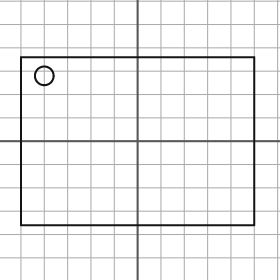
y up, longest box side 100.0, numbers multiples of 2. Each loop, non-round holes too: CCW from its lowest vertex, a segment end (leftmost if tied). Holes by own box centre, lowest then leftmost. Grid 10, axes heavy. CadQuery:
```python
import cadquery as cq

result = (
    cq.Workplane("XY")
    .moveTo(-50.0, -36.0)
    .lineTo(50.0, -36.0)
    .lineTo(50.0, 36.0)
    .lineTo(-50.0, 36.0)
    .close()
    .moveTo(-40.0, 28.0)
    .circle(4.0)
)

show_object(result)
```